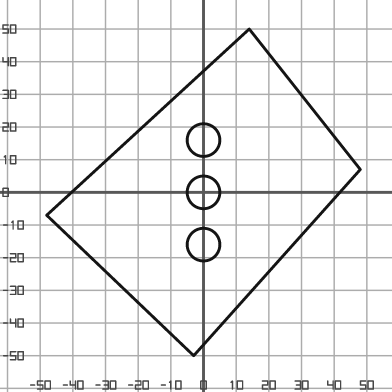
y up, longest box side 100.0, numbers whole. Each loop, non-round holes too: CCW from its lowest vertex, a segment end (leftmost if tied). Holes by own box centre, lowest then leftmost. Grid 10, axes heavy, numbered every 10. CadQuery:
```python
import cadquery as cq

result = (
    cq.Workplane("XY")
    .moveTo(-3.0, -50.0)
    .lineTo(48.0, 7.0)
    .lineTo(14.0, 50.0)
    .lineTo(-48.0, -7.0)
    .close()
    .moveTo(0.0, -16.0)
    .circle(5.0)
    .moveTo(0.0, 0.0)
    .circle(5.0)
    .moveTo(0.0, 16.0)
    .circle(5.0)
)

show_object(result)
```